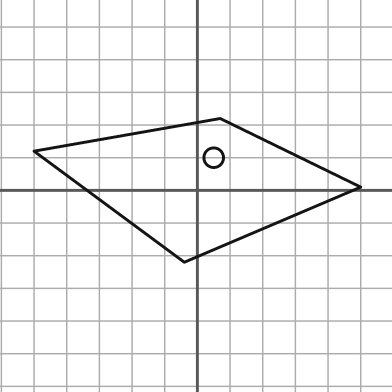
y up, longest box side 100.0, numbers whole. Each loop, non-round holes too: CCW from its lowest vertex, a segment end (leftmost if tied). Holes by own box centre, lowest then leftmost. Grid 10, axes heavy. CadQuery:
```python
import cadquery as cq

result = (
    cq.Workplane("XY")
    .moveTo(-4.0, -22.0)
    .lineTo(50.0, 1.0)
    .lineTo(7.0, 22.0)
    .lineTo(-50.0, 12.0)
    .close()
    .moveTo(5.0, 10.0)
    .circle(3.0)
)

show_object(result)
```